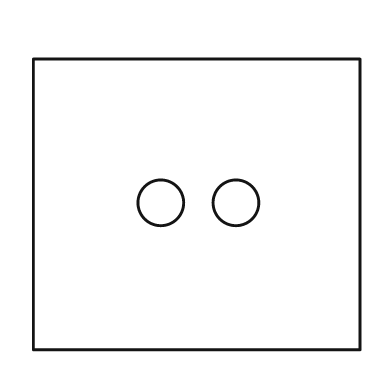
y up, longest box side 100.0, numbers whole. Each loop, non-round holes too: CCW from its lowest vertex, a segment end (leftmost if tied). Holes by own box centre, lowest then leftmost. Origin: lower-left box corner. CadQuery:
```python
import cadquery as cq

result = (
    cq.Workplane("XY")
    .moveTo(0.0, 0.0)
    .lineTo(100.0, 0.0)
    .lineTo(100.0, 89.0)
    .lineTo(0.0, 89.0)
    .close()
    .moveTo(39.0, 45.0)
    .circle(7.0)
    .moveTo(62.0, 45.0)
    .circle(7.0)
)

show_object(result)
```